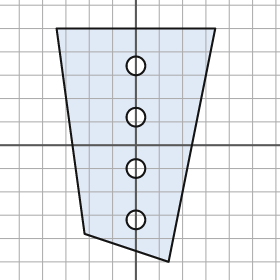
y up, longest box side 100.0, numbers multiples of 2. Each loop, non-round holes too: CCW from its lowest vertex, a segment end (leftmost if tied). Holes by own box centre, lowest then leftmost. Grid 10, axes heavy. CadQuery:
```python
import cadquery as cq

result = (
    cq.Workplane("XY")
    .moveTo(14.0, -50.0)
    .lineTo(34.0, 50.0)
    .lineTo(-34.0, 50.0)
    .lineTo(-22.0, -38.0)
    .close()
    .moveTo(0.0, -32.0)
    .circle(4.0)
    .moveTo(0.0, -10.0)
    .circle(4.0)
    .moveTo(0.0, 12.0)
    .circle(4.0)
    .moveTo(0.0, 34.0)
    .circle(4.0)
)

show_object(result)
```